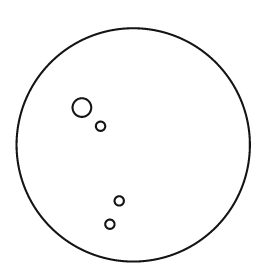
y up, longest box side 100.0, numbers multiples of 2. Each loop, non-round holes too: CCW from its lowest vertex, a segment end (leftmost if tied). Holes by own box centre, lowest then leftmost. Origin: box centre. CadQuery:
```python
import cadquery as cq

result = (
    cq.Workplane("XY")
    .moveTo(0.0, 0.0)
    .circle(50.0)
    .moveTo(-10.0, -34.0)
    .circle(2.0)
    .moveTo(-6.0, -24.0)
    .circle(2.0)
    .moveTo(-14.0, 8.0)
    .circle(2.0)
    .moveTo(-22.0, 16.0)
    .circle(4.0)
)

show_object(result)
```